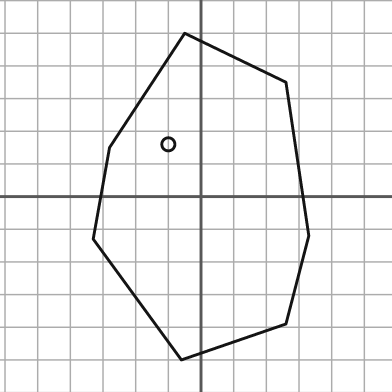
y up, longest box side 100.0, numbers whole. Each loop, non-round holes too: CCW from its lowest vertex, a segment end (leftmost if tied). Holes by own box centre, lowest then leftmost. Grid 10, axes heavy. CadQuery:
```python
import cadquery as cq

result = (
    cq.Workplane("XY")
    .moveTo(-6.0, -50.0)
    .lineTo(26.0, -39.0)
    .lineTo(33.0, -12.0)
    .lineTo(26.0, 35.0)
    .lineTo(-5.0, 50.0)
    .lineTo(-28.0, 15.0)
    .lineTo(-33.0, -13.0)
    .close()
    .moveTo(-10.0, 16.0)
    .circle(2.0)
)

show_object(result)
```